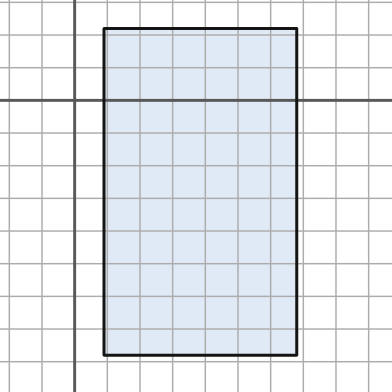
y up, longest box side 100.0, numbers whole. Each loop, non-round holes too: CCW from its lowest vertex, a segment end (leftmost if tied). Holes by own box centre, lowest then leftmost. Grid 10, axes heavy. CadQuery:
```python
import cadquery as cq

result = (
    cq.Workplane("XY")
    .moveTo(9.0, -78.0)
    .lineTo(68.0, -78.0)
    .lineTo(68.0, 22.0)
    .lineTo(9.0, 22.0)
    .close()
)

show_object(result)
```